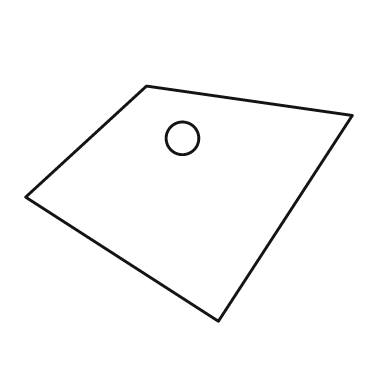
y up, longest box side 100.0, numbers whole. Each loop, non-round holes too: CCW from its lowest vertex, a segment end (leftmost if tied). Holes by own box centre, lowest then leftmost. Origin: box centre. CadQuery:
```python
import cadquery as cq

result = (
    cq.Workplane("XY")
    .moveTo(9.0, -36.0)
    .lineTo(50.0, 27.0)
    .lineTo(-13.0, 36.0)
    .lineTo(-50.0, 2.0)
    .close()
    .moveTo(-2.0, 20.0)
    .circle(5.0)
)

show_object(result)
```